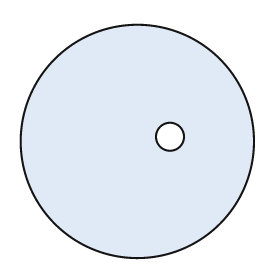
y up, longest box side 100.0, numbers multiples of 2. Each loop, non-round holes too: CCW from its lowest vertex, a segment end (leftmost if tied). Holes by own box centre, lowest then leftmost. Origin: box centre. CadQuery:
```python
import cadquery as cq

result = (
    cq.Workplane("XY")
    .moveTo(0.0, 0.0)
    .circle(50.0)
    .moveTo(14.0, 2.0)
    .circle(6.0)
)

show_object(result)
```